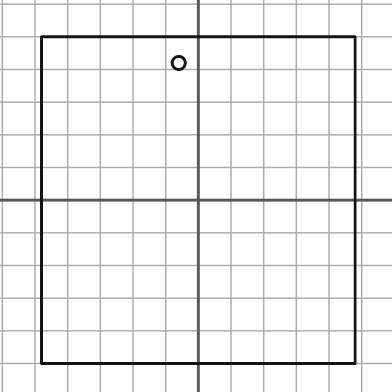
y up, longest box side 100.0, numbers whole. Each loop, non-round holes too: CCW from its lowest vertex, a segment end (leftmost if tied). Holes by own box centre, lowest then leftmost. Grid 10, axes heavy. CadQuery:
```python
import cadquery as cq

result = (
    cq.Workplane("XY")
    .moveTo(-48.0, -50.0)
    .lineTo(48.0, -50.0)
    .lineTo(48.0, 50.0)
    .lineTo(-48.0, 50.0)
    .close()
    .moveTo(-6.0, 42.0)
    .circle(2.0)
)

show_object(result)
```